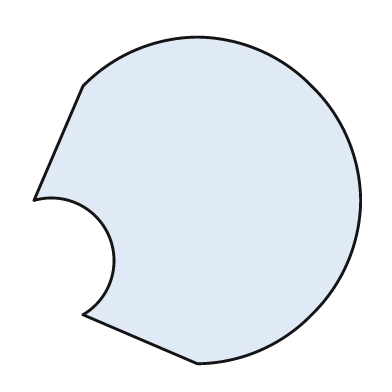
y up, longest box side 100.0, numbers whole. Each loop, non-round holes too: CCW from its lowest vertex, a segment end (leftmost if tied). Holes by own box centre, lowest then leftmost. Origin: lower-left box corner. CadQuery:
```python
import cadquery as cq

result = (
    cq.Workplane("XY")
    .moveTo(50.0, 0.0)
    .threePointArc((69.0, 4.0), (85.0, 15.0))
    .threePointArc((96.0, 31.0), (100.0, 50.0))
    .threePointArc((96.0, 69.0), (85.0, 85.0))
    .threePointArc((69.0, 96.0), (50.0, 100.0))
    .threePointArc((31.0, 96.0), (15.0, 85.0))
    .lineTo(0.0, 50.0)
    .threePointArc((23.0, 39.0), (15.0, 15.0))
    .close()
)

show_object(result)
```